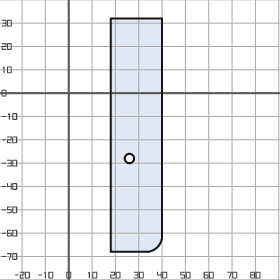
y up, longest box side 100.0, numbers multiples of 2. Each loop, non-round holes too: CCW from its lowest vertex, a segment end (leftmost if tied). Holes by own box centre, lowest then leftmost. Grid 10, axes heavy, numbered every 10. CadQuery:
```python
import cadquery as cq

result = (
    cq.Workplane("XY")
    .moveTo(18.0, -68.0)
    .lineTo(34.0, -68.0)
    .threePointArc((38.0, -66.0), (40.0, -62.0))
    .lineTo(40.0, 32.0)
    .lineTo(18.0, 32.0)
    .close()
    .moveTo(26.0, -28.0)
    .circle(2.0)
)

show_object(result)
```